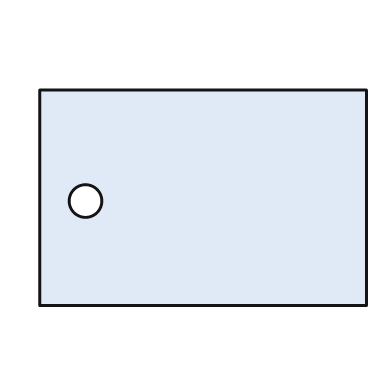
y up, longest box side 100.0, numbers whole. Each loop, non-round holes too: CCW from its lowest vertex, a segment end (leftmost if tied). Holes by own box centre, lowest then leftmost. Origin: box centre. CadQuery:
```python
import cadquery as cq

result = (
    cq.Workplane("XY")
    .moveTo(-50.0, -33.0)
    .lineTo(50.0, -33.0)
    .lineTo(50.0, 33.0)
    .lineTo(-50.0, 33.0)
    .close()
    .moveTo(-36.0, -1.0)
    .circle(5.0)
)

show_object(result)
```